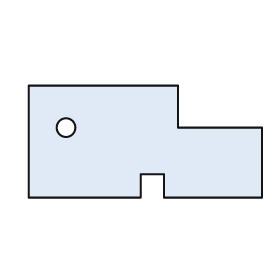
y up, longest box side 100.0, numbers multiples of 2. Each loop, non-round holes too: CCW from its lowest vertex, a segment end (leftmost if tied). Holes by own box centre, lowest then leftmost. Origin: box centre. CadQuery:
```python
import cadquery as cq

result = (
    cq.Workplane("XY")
    .moveTo(-50.0, -24.0)
    .lineTo(-2.0, -24.0)
    .lineTo(-2.0, -14.0)
    .lineTo(8.0, -14.0)
    .lineTo(8.0, -24.0)
    .lineTo(50.0, -24.0)
    .lineTo(50.0, 6.0)
    .lineTo(14.0, 6.0)
    .lineTo(14.0, 24.0)
    .lineTo(-50.0, 24.0)
    .close()
    .moveTo(-34.0, 6.0)
    .circle(4.0)
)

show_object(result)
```